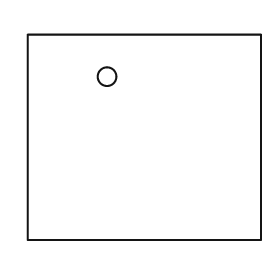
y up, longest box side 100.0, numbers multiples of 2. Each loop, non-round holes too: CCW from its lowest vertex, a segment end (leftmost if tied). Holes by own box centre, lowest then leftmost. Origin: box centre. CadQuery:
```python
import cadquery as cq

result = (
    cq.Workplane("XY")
    .moveTo(-50.0, -44.0)
    .lineTo(50.0, -44.0)
    .lineTo(50.0, 44.0)
    .lineTo(-50.0, 44.0)
    .close()
    .moveTo(-16.0, 26.0)
    .circle(4.0)
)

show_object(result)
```